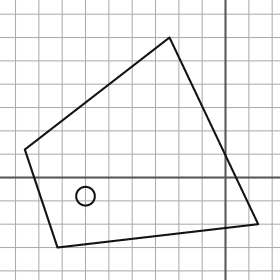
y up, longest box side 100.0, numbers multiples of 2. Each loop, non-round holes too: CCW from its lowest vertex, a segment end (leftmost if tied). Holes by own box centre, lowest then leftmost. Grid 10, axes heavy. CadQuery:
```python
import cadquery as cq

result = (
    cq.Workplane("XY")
    .moveTo(-72.0, -30.0)
    .lineTo(14.0, -20.0)
    .lineTo(-24.0, 60.0)
    .lineTo(-86.0, 12.0)
    .close()
    .moveTo(-60.0, -8.0)
    .circle(4.0)
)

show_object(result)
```